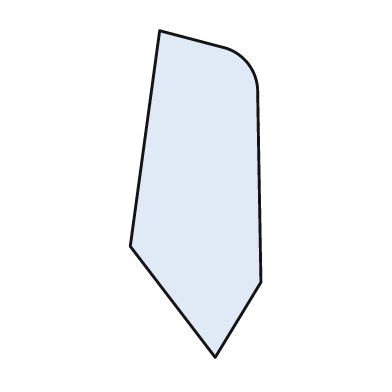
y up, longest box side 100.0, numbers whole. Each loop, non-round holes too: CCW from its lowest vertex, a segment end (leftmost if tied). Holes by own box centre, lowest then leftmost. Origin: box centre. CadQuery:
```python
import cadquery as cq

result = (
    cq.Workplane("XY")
    .moveTo(6.0, -50.0)
    .lineTo(20.0, -27.0)
    .lineTo(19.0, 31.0)
    .threePointArc((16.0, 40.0), (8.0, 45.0))
    .lineTo(-11.0, 50.0)
    .lineTo(-20.0, -16.0)
    .close()
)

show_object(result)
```